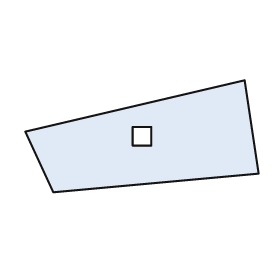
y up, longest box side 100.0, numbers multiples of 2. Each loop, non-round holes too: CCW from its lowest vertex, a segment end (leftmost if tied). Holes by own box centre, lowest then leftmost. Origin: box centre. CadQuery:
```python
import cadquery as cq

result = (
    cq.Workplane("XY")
    .moveTo(-38.0, -24.0)
    .lineTo(50.0, -16.0)
    .lineTo(44.0, 24.0)
    .lineTo(-50.0, 2.0)
    .close()
    .moveTo(-4.0, -4.0)
    .lineTo(4.0, -4.0)
    .lineTo(4.0, 4.0)
    .lineTo(-4.0, 4.0)
    .close()
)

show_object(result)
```